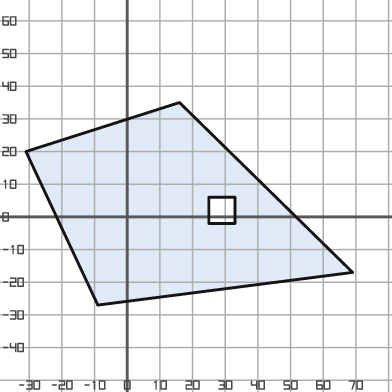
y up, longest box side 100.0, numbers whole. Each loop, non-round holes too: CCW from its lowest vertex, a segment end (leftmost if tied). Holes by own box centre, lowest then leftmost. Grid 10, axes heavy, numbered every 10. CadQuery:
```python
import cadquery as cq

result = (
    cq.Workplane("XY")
    .moveTo(-9.0, -27.0)
    .lineTo(69.0, -17.0)
    .lineTo(16.0, 35.0)
    .lineTo(-31.0, 20.0)
    .close()
    .moveTo(25.0, -2.0)
    .lineTo(33.0, -2.0)
    .lineTo(33.0, 6.0)
    .lineTo(25.0, 6.0)
    .close()
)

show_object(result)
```